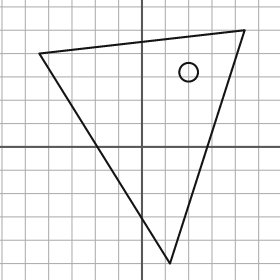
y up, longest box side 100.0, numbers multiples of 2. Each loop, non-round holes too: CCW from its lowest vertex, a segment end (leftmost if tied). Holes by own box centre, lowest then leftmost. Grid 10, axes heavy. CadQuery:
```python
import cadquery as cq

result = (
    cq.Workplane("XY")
    .moveTo(12.0, -50.0)
    .lineTo(44.0, 50.0)
    .lineTo(-44.0, 40.0)
    .close()
    .moveTo(20.0, 32.0)
    .circle(4.0)
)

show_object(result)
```